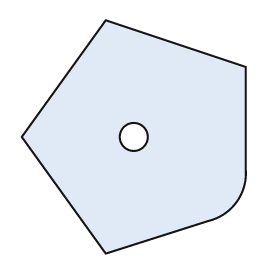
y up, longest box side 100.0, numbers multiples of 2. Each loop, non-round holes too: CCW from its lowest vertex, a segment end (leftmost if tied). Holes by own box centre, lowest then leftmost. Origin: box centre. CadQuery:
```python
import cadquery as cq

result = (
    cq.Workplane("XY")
    .moveTo(-12.0, -50.0)
    .lineTo(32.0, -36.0)
    .threePointArc((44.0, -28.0), (48.0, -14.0))
    .lineTo(48.0, 30.0)
    .lineTo(-12.0, 50.0)
    .lineTo(-48.0, 0.0)
    .close()
    .moveTo(0.0, 0.0)
    .circle(6.0)
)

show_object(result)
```